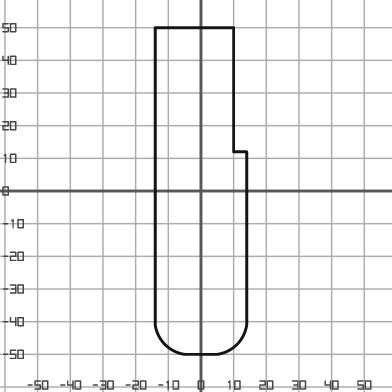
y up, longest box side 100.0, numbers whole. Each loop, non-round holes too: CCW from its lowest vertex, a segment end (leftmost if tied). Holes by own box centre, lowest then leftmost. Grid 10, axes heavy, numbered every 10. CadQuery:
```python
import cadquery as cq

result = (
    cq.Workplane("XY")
    .moveTo(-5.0, -50.0)
    .lineTo(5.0, -50.0)
    .threePointArc((11.0, -47.0), (14.0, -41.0))
    .lineTo(14.0, 12.0)
    .lineTo(10.0, 12.0)
    .lineTo(10.0, 50.0)
    .lineTo(-14.0, 50.0)
    .lineTo(-14.0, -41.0)
    .threePointArc((-11.0, -47.0), (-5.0, -50.0))
    .close()
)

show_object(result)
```